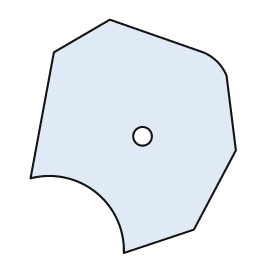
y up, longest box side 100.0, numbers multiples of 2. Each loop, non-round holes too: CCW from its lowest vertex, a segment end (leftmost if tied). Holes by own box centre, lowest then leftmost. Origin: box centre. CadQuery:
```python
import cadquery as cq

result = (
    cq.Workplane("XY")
    .moveTo(-4.0, -50.0)
    .lineTo(26.0, -40.0)
    .lineTo(44.0, -6.0)
    .lineTo(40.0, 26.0)
    .threePointArc((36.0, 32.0), (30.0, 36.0))
    .lineTo(-10.0, 50.0)
    .lineTo(-34.0, 36.0)
    .lineTo(-44.0, -18.0)
    .threePointArc((-16.0, -24.0), (-4.0, -50.0))
    .close()
    .moveTo(4.0, 0.0)
    .circle(4.0)
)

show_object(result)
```